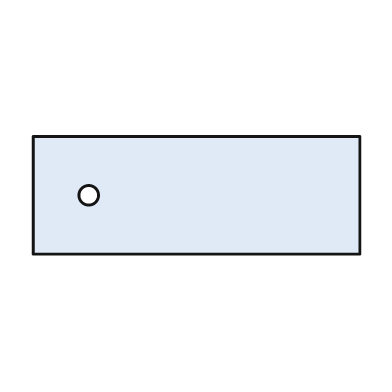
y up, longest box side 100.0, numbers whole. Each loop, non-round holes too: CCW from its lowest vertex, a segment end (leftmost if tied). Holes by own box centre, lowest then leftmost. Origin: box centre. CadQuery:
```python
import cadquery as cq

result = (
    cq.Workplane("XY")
    .moveTo(-50.0, -18.0)
    .lineTo(50.0, -18.0)
    .lineTo(50.0, 18.0)
    .lineTo(-50.0, 18.0)
    .close()
    .moveTo(-33.0, 0.0)
    .circle(3.0)
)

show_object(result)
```